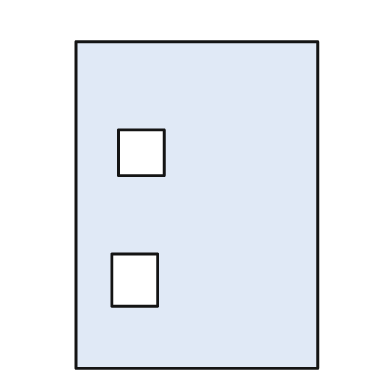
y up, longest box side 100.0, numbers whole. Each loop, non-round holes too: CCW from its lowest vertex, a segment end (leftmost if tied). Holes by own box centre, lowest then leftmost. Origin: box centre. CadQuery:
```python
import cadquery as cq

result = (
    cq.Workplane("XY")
    .moveTo(-37.0, -50.0)
    .lineTo(37.0, -50.0)
    .lineTo(37.0, 50.0)
    .lineTo(-37.0, 50.0)
    .close()
    .moveTo(-26.0, -31.0)
    .lineTo(-12.0, -31.0)
    .lineTo(-12.0, -15.0)
    .lineTo(-26.0, -15.0)
    .close()
    .moveTo(-24.0, 9.0)
    .lineTo(-10.0, 9.0)
    .lineTo(-10.0, 23.0)
    .lineTo(-24.0, 23.0)
    .close()
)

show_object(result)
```